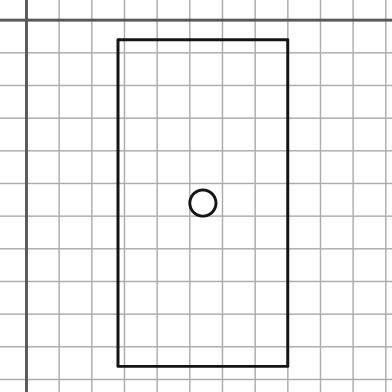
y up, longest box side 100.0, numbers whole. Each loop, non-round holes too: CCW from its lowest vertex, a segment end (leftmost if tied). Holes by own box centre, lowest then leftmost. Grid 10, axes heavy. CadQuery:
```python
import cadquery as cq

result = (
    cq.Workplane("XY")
    .moveTo(28.0, -106.0)
    .lineTo(80.0, -106.0)
    .lineTo(80.0, -6.0)
    .lineTo(28.0, -6.0)
    .close()
    .moveTo(54.0, -56.0)
    .circle(4.0)
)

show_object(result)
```